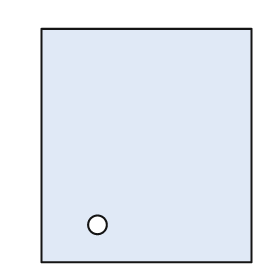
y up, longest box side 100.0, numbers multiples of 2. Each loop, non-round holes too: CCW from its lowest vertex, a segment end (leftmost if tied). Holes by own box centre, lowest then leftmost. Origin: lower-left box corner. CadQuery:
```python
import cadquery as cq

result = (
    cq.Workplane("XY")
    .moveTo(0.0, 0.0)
    .lineTo(90.0, 0.0)
    .lineTo(90.0, 100.0)
    .lineTo(0.0, 100.0)
    .close()
    .moveTo(24.0, 16.0)
    .circle(4.0)
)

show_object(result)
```